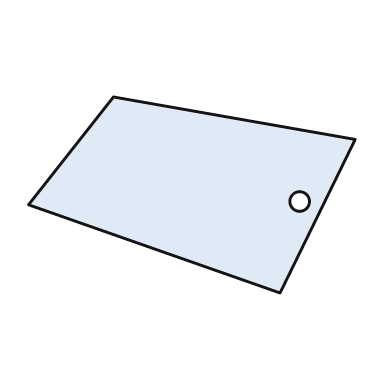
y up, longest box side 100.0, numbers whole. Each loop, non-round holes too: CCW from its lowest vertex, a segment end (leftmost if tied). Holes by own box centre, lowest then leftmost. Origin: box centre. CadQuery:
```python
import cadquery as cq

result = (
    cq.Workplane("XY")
    .moveTo(27.0, -30.0)
    .lineTo(50.0, 17.0)
    .lineTo(-24.0, 30.0)
    .lineTo(-50.0, -3.0)
    .close()
    .moveTo(33.0, -2.0)
    .circle(3.0)
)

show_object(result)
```